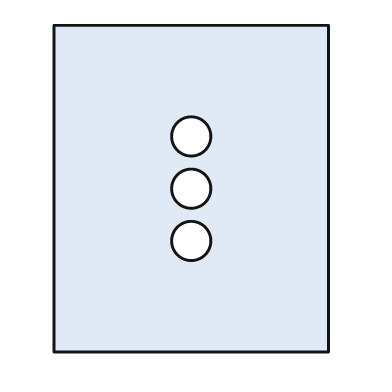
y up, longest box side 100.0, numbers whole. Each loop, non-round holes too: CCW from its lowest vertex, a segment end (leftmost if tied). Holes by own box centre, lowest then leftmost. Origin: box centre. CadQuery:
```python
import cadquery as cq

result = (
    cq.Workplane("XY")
    .moveTo(-42.0, -50.0)
    .lineTo(42.0, -50.0)
    .lineTo(42.0, 50.0)
    .lineTo(-42.0, 50.0)
    .close()
    .moveTo(0.0, -16.0)
    .circle(6.0)
    .moveTo(0.0, 0.0)
    .circle(6.0)
    .moveTo(0.0, 16.0)
    .circle(6.0)
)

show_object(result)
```